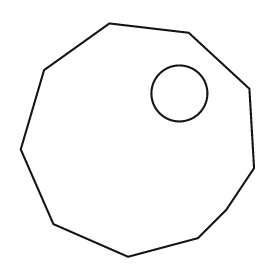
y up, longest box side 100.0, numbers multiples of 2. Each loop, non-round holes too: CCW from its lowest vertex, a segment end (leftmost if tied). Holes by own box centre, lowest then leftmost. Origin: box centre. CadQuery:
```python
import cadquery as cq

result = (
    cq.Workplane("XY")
    .moveTo(-4.0, -50.0)
    .lineTo(26.0, -42.0)
    .lineTo(38.0, -30.0)
    .lineTo(50.0, -12.0)
    .lineTo(48.0, 22.0)
    .lineTo(22.0, 46.0)
    .lineTo(-12.0, 50.0)
    .lineTo(-40.0, 30.0)
    .lineTo(-50.0, -4.0)
    .lineTo(-36.0, -36.0)
    .close()
    .moveTo(18.0, 20.0)
    .circle(12.0)
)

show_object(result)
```